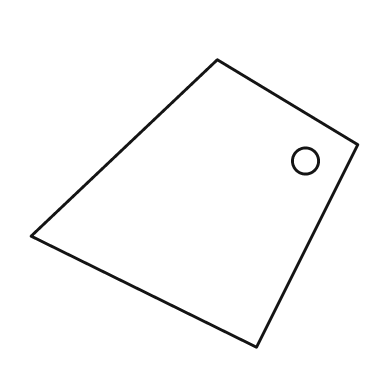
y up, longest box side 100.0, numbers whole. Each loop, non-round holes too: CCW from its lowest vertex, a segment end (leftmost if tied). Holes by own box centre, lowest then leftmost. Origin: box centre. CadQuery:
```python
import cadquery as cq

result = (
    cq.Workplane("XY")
    .moveTo(19.0, -44.0)
    .lineTo(50.0, 18.0)
    .lineTo(7.0, 44.0)
    .lineTo(-50.0, -10.0)
    .close()
    .moveTo(34.0, 13.0)
    .circle(4.0)
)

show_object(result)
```